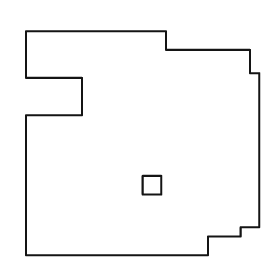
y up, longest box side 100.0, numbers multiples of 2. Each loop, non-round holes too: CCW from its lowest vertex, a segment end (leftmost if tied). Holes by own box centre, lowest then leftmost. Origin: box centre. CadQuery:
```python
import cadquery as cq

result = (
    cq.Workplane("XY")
    .moveTo(-50.0, -48.0)
    .lineTo(28.0, -48.0)
    .lineTo(28.0, -40.0)
    .lineTo(42.0, -40.0)
    .lineTo(42.0, -36.0)
    .lineTo(50.0, -36.0)
    .lineTo(50.0, 30.0)
    .lineTo(46.0, 30.0)
    .lineTo(46.0, 40.0)
    .lineTo(10.0, 40.0)
    .lineTo(10.0, 48.0)
    .lineTo(-50.0, 48.0)
    .lineTo(-50.0, 28.0)
    .lineTo(-26.0, 28.0)
    .lineTo(-26.0, 12.0)
    .lineTo(-50.0, 12.0)
    .close()
    .moveTo(0.0, -22.0)
    .lineTo(8.0, -22.0)
    .lineTo(8.0, -14.0)
    .lineTo(0.0, -14.0)
    .close()
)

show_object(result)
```